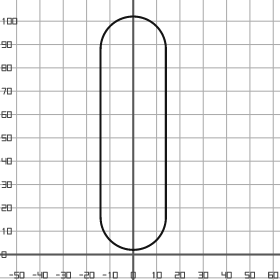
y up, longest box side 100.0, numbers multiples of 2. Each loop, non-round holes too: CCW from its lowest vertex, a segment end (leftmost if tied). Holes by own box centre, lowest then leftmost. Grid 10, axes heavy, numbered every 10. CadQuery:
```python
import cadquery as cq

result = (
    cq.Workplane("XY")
    .moveTo(-14.0, 16.0)
    .threePointArc((0.0, 2.0), (14.0, 16.0))
    .lineTo(14.0, 88.0)
    .threePointArc((0.0, 102.0), (-14.0, 88.0))
    .close()
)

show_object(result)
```